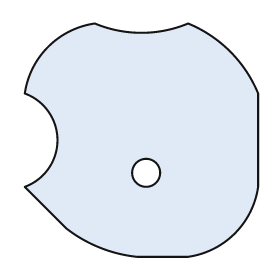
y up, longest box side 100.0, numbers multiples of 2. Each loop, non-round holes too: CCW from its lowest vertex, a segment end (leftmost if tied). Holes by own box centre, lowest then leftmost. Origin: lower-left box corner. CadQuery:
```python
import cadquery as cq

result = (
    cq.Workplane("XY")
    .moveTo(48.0, 0.0)
    .lineTo(70.0, 0.0)
    .threePointArc((90.0, 10.0), (100.0, 30.0))
    .lineTo(100.0, 70.0)
    .threePointArc((88.0, 88.0), (70.0, 100.0))
    .threePointArc((50.0, 96.0), (30.0, 100.0))
    .threePointArc((10.0, 90.0), (0.0, 70.0))
    .threePointArc((14.0, 50.0), (0.0, 30.0))
    .lineTo(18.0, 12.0)
    .threePointArc((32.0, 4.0), (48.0, 0.0))
    .close()
    .moveTo(52.0, 36.0)
    .circle(6.0)
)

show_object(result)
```